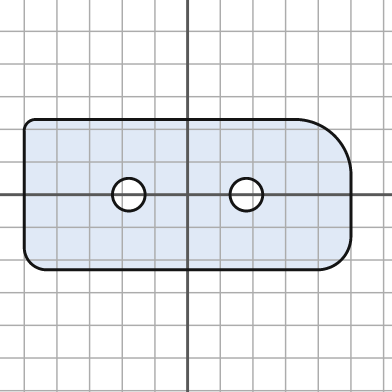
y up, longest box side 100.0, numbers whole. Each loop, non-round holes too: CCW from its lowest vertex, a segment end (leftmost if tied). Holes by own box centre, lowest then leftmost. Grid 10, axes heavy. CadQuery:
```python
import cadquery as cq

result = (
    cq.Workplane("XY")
    .moveTo(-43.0, -23.0)
    .lineTo(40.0, -23.0)
    .threePointArc((47.0, -20.0), (50.0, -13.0))
    .lineTo(50.0, 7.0)
    .threePointArc((45.0, 18.0), (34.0, 23.0))
    .lineTo(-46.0, 23.0)
    .threePointArc((-49.0, 22.0), (-50.0, 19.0))
    .lineTo(-50.0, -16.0)
    .threePointArc((-48.0, -21.0), (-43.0, -23.0))
    .close()
    .moveTo(-18.0, 0.0)
    .circle(5.0)
    .moveTo(18.0, 0.0)
    .circle(5.0)
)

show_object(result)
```